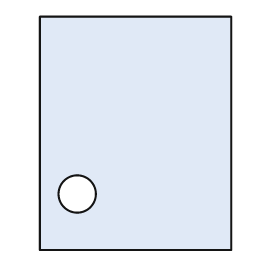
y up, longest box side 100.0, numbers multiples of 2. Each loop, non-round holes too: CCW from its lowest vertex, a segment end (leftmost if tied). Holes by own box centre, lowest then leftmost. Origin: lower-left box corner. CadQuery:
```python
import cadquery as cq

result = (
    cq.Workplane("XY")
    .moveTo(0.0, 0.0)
    .lineTo(82.0, 0.0)
    .lineTo(82.0, 100.0)
    .lineTo(0.0, 100.0)
    .close()
    .moveTo(16.0, 24.0)
    .circle(8.0)
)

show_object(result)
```